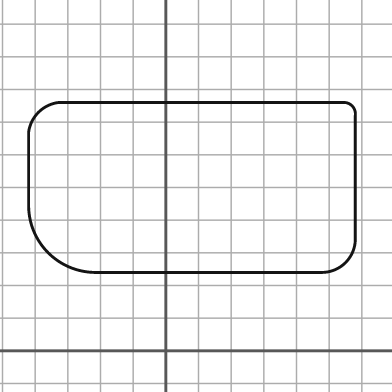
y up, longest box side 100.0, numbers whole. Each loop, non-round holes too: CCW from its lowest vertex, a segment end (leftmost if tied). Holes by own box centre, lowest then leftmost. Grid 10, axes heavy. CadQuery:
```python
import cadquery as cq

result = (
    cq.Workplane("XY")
    .moveTo(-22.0, 24.0)
    .lineTo(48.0, 24.0)
    .threePointArc((55.0, 27.0), (58.0, 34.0))
    .lineTo(58.0, 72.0)
    .threePointArc((57.0, 75.0), (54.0, 76.0))
    .lineTo(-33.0, 76.0)
    .threePointArc((-39.0, 73.0), (-42.0, 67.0))
    .lineTo(-42.0, 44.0)
    .threePointArc((-36.0, 30.0), (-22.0, 24.0))
    .close()
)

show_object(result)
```